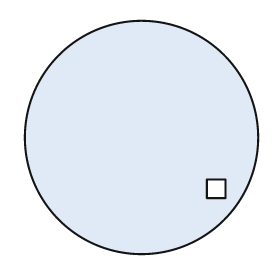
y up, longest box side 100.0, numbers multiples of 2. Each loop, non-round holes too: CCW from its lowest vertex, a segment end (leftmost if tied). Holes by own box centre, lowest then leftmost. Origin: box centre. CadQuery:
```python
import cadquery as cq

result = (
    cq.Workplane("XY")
    .moveTo(0.0, 0.0)
    .circle(50.0)
    .moveTo(28.0, -26.0)
    .lineTo(36.0, -26.0)
    .lineTo(36.0, -18.0)
    .lineTo(28.0, -18.0)
    .close()
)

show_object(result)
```